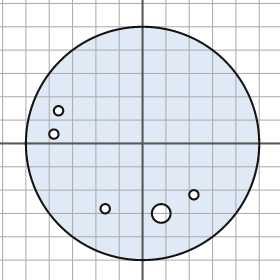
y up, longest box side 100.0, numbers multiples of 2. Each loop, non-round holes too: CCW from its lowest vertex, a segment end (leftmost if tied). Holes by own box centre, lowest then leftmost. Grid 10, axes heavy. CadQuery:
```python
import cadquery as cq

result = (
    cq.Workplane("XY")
    .moveTo(0.0, 0.0)
    .circle(50.0)
    .moveTo(8.0, -30.0)
    .circle(4.0)
    .moveTo(-16.0, -28.0)
    .circle(2.0)
    .moveTo(22.0, -22.0)
    .circle(2.0)
    .moveTo(-38.0, 4.0)
    .circle(2.0)
    .moveTo(-36.0, 14.0)
    .circle(2.0)
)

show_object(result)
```